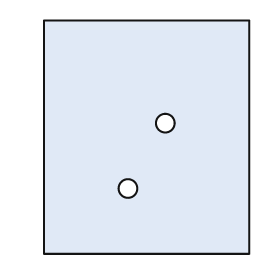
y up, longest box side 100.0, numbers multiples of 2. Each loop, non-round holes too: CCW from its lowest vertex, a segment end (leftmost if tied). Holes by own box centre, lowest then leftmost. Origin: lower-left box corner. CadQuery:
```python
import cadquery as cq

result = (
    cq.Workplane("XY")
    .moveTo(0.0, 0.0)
    .lineTo(88.0, 0.0)
    .lineTo(88.0, 100.0)
    .lineTo(0.0, 100.0)
    .close()
    .moveTo(36.0, 28.0)
    .circle(4.0)
    .moveTo(52.0, 56.0)
    .circle(4.0)
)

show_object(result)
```